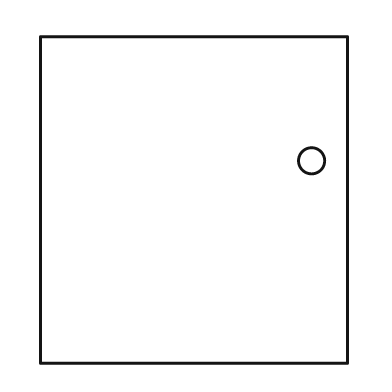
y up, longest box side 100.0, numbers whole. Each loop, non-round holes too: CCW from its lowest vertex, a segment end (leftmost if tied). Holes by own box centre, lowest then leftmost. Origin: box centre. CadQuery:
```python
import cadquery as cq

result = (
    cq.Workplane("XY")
    .moveTo(-47.0, -50.0)
    .lineTo(47.0, -50.0)
    .lineTo(47.0, 50.0)
    .lineTo(-47.0, 50.0)
    .close()
    .moveTo(36.0, 12.0)
    .circle(4.0)
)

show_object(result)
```